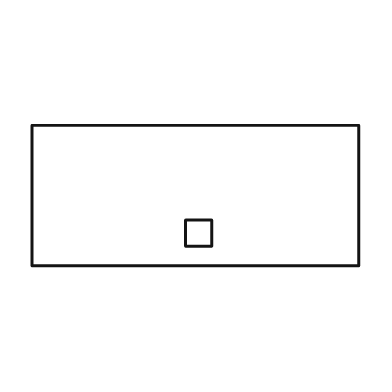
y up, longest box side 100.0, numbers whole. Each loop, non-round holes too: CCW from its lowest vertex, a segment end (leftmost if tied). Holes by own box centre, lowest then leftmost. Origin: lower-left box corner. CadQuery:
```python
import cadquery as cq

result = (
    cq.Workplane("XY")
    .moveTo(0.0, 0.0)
    .lineTo(100.0, 0.0)
    .lineTo(100.0, 43.0)
    .lineTo(0.0, 43.0)
    .close()
    .moveTo(47.0, 6.0)
    .lineTo(55.0, 6.0)
    .lineTo(55.0, 14.0)
    .lineTo(47.0, 14.0)
    .close()
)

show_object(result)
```